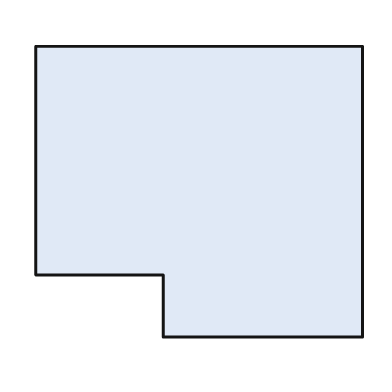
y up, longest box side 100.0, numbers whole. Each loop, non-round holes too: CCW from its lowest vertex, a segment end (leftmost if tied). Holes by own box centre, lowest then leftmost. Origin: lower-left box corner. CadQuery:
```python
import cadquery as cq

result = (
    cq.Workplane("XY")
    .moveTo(39.0, 0.0)
    .lineTo(100.0, 0.0)
    .lineTo(100.0, 89.0)
    .lineTo(0.0, 89.0)
    .lineTo(0.0, 19.0)
    .lineTo(39.0, 19.0)
    .close()
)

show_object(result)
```